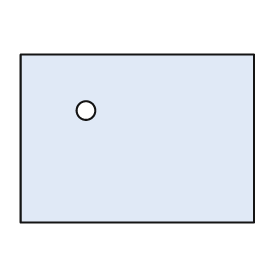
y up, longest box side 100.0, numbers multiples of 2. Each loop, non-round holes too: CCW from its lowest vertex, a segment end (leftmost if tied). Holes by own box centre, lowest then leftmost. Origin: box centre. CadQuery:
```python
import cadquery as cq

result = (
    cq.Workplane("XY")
    .moveTo(-50.0, -36.0)
    .lineTo(50.0, -36.0)
    .lineTo(50.0, 36.0)
    .lineTo(-50.0, 36.0)
    .close()
    .moveTo(-22.0, 12.0)
    .circle(4.0)
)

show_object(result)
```